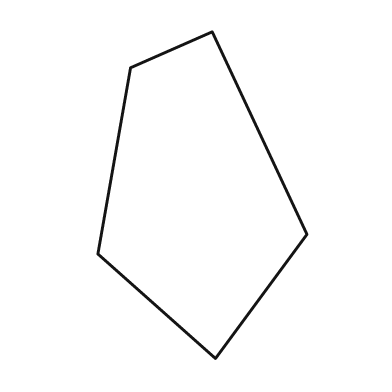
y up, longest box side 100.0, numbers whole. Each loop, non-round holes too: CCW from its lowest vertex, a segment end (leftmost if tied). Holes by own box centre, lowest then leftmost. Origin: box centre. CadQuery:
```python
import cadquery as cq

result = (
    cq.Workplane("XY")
    .moveTo(4.0, -50.0)
    .lineTo(32.0, -12.0)
    .lineTo(3.0, 50.0)
    .lineTo(-22.0, 39.0)
    .lineTo(-32.0, -18.0)
    .close()
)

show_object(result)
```